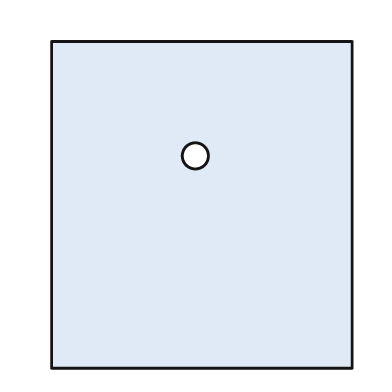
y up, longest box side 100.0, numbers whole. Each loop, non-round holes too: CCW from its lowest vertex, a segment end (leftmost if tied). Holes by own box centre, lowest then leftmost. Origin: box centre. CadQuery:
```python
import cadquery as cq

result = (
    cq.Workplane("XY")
    .moveTo(-46.0, -50.0)
    .lineTo(46.0, -50.0)
    .lineTo(46.0, 50.0)
    .lineTo(-46.0, 50.0)
    .close()
    .moveTo(-2.0, 15.0)
    .circle(4.0)
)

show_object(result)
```